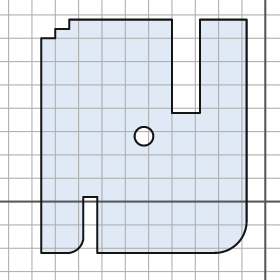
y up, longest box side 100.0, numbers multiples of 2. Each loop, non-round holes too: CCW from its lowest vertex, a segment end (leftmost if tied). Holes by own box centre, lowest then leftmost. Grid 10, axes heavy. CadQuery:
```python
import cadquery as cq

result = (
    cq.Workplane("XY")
    .moveTo(-96.0, -22.0)
    .lineTo(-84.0, -22.0)
    .threePointArc((-80.0, -20.0), (-78.0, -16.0))
    .lineTo(-78.0, 2.0)
    .lineTo(-72.0, 2.0)
    .lineTo(-72.0, -22.0)
    .lineTo(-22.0, -22.0)
    .threePointArc((-12.0, -18.0), (-8.0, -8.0))
    .lineTo(-8.0, 78.0)
    .lineTo(-28.0, 78.0)
    .lineTo(-28.0, 38.0)
    .lineTo(-40.0, 38.0)
    .lineTo(-40.0, 78.0)
    .lineTo(-84.0, 78.0)
    .lineTo(-84.0, 74.0)
    .lineTo(-90.0, 74.0)
    .lineTo(-90.0, 70.0)
    .lineTo(-96.0, 70.0)
    .close()
    .moveTo(-52.0, 28.0)
    .circle(4.0)
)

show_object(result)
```